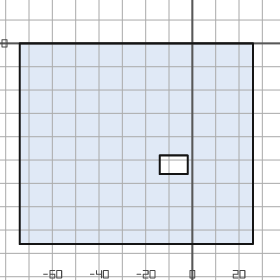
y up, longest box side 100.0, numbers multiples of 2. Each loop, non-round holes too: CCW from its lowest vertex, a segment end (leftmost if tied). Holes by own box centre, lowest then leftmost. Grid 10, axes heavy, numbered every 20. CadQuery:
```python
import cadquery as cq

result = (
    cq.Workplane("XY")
    .moveTo(-74.0, -86.0)
    .lineTo(26.0, -86.0)
    .lineTo(26.0, 0.0)
    .lineTo(-74.0, 0.0)
    .close()
    .moveTo(-14.0, -56.0)
    .lineTo(-2.0, -56.0)
    .lineTo(-2.0, -48.0)
    .lineTo(-14.0, -48.0)
    .close()
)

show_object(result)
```